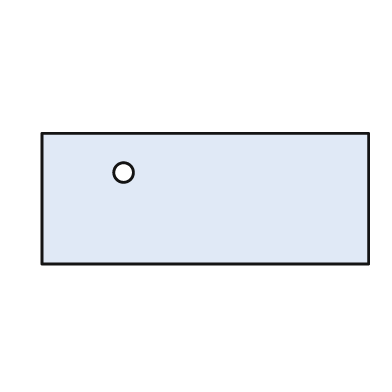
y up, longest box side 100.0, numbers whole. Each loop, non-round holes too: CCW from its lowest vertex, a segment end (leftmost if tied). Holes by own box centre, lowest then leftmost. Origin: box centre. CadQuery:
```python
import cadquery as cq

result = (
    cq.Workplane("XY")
    .moveTo(-50.0, -20.0)
    .lineTo(50.0, -20.0)
    .lineTo(50.0, 20.0)
    .lineTo(-50.0, 20.0)
    .close()
    .moveTo(-25.0, 8.0)
    .circle(3.0)
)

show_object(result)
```